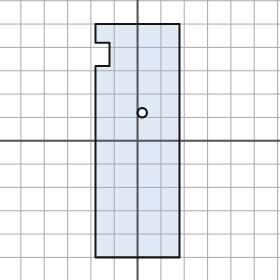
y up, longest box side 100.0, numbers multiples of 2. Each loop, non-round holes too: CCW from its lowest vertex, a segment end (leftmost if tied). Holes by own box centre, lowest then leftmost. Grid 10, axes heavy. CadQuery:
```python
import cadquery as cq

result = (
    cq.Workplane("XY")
    .moveTo(-18.0, -50.0)
    .lineTo(18.0, -50.0)
    .lineTo(18.0, 50.0)
    .lineTo(-18.0, 50.0)
    .lineTo(-18.0, 42.0)
    .lineTo(-12.0, 42.0)
    .lineTo(-12.0, 32.0)
    .lineTo(-18.0, 32.0)
    .close()
    .moveTo(2.0, 12.0)
    .circle(2.0)
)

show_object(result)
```